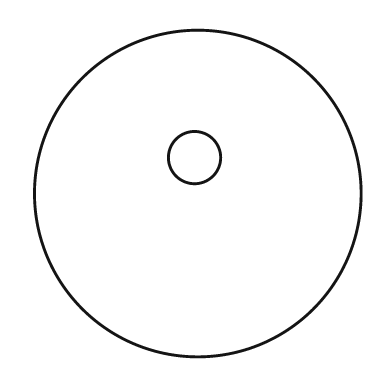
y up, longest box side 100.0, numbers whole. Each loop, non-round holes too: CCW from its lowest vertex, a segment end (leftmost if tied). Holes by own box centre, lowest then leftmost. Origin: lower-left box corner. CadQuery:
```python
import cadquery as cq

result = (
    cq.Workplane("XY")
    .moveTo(50.0, 50.0)
    .circle(50.0)
    .moveTo(49.0, 61.0)
    .circle(8.0)
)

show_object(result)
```